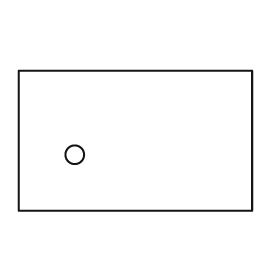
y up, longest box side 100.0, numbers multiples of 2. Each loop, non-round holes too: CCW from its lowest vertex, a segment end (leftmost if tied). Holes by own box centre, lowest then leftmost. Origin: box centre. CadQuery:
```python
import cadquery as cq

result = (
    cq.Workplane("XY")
    .moveTo(-50.0, -30.0)
    .lineTo(50.0, -30.0)
    .lineTo(50.0, 30.0)
    .lineTo(-50.0, 30.0)
    .close()
    .moveTo(-26.0, -6.0)
    .circle(4.0)
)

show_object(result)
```